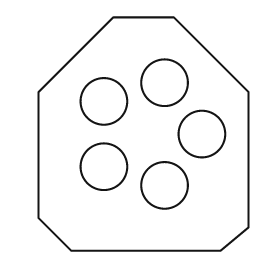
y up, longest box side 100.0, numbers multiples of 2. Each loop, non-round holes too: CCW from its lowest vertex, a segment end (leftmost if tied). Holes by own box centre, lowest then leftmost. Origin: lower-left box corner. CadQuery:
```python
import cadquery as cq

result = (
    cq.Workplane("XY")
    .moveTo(14.0, 0.0)
    .lineTo(78.0, 0.0)
    .lineTo(90.0, 10.0)
    .lineTo(90.0, 68.0)
    .lineTo(58.0, 100.0)
    .lineTo(32.0, 100.0)
    .lineTo(0.0, 68.0)
    .lineTo(0.0, 14.0)
    .close()
    .moveTo(54.0, 28.0)
    .circle(10.0)
    .moveTo(28.0, 36.0)
    .circle(10.0)
    .moveTo(70.0, 50.0)
    .circle(10.0)
    .moveTo(28.0, 64.0)
    .circle(10.0)
    .moveTo(54.0, 72.0)
    .circle(10.0)
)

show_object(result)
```